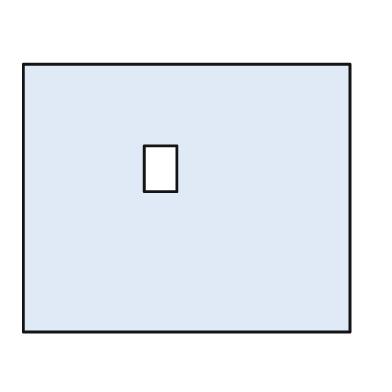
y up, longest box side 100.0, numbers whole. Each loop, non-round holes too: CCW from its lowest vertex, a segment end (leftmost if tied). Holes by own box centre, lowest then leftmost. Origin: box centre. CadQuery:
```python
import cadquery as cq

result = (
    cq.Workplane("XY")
    .moveTo(-50.0, -41.0)
    .lineTo(50.0, -41.0)
    .lineTo(50.0, 41.0)
    .lineTo(-50.0, 41.0)
    .close()
    .moveTo(-13.0, 2.0)
    .lineTo(-3.0, 2.0)
    .lineTo(-3.0, 16.0)
    .lineTo(-13.0, 16.0)
    .close()
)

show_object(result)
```